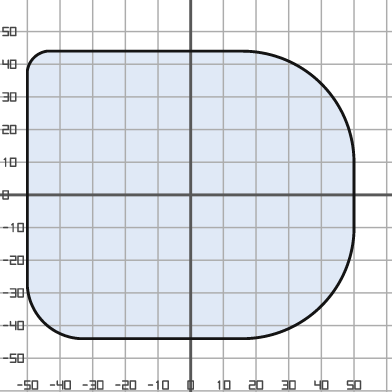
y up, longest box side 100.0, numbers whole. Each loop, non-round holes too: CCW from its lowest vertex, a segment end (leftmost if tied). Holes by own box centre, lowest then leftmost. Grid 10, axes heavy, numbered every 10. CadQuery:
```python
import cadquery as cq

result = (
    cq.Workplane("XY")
    .moveTo(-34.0, -44.0)
    .lineTo(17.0, -44.0)
    .threePointArc((40.0, -34.0), (50.0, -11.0))
    .lineTo(50.0, 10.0)
    .threePointArc((40.0, 34.0), (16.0, 44.0))
    .lineTo(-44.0, 44.0)
    .threePointArc((-48.0, 42.0), (-50.0, 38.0))
    .lineTo(-50.0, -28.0)
    .threePointArc((-45.0, -39.0), (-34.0, -44.0))
    .close()
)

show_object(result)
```